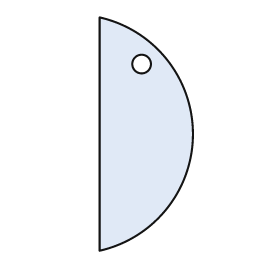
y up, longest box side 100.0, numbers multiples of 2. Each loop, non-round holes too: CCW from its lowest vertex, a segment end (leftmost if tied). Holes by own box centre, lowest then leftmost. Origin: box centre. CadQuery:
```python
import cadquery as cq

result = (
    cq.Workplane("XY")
    .moveTo(-20.0, -50.0)
    .threePointArc((20.0, 0.0), (-20.0, 50.0))
    .close()
    .moveTo(-2.0, 30.0)
    .circle(4.0)
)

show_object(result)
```